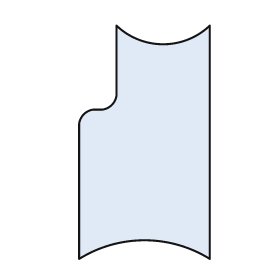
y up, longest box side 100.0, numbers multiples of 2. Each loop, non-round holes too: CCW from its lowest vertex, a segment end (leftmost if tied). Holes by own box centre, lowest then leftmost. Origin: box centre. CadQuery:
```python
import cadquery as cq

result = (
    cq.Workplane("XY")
    .moveTo(-28.0, -50.0)
    .threePointArc((0.0, -42.0), (28.0, -50.0))
    .lineTo(28.0, 50.0)
    .threePointArc((8.0, 42.0), (-12.0, 50.0))
    .lineTo(-12.0, 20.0)
    .threePointArc((-14.0, 16.0), (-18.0, 14.0))
    .lineTo(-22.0, 14.0)
    .threePointArc((-26.0, 12.0), (-28.0, 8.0))
    .close()
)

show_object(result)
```